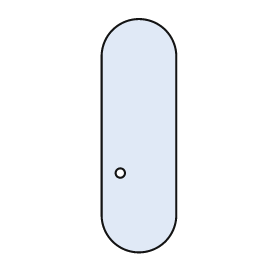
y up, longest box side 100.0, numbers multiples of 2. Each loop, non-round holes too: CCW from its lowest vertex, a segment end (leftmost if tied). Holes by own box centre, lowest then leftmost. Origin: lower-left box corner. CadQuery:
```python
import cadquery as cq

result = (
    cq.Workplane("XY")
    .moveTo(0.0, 16.0)
    .threePointArc((16.0, 0.0), (32.0, 16.0))
    .lineTo(32.0, 84.0)
    .threePointArc((16.0, 100.0), (0.0, 84.0))
    .close()
    .moveTo(8.0, 34.0)
    .circle(2.0)
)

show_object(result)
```